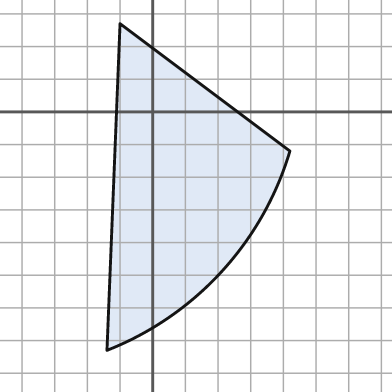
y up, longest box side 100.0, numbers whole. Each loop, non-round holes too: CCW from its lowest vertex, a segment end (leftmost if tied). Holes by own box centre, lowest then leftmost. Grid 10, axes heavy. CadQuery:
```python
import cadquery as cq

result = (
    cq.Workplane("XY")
    .moveTo(-14.0, -73.0)
    .threePointArc((21.0, -49.0), (42.0, -12.0))
    .lineTo(-10.0, 27.0)
    .close()
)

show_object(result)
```